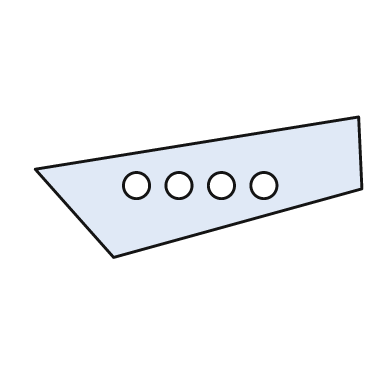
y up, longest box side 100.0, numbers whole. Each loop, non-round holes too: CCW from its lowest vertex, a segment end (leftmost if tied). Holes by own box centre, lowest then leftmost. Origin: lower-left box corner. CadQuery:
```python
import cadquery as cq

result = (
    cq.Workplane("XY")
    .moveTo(24.0, 0.0)
    .lineTo(100.0, 21.0)
    .lineTo(99.0, 43.0)
    .lineTo(0.0, 27.0)
    .close()
    .moveTo(31.0, 22.0)
    .circle(4.0)
    .moveTo(44.0, 22.0)
    .circle(4.0)
    .moveTo(57.0, 22.0)
    .circle(4.0)
    .moveTo(70.0, 22.0)
    .circle(4.0)
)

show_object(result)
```